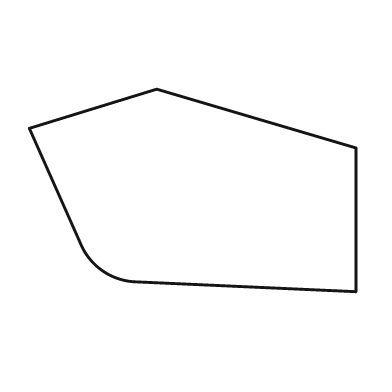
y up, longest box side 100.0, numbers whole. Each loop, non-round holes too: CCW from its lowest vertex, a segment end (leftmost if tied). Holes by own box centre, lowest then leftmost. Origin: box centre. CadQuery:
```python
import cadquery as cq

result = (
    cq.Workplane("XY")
    .moveTo(50.0, -31.0)
    .lineTo(50.0, 13.0)
    .lineTo(-11.0, 31.0)
    .lineTo(-50.0, 19.0)
    .lineTo(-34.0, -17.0)
    .threePointArc((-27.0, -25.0), (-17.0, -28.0))
    .close()
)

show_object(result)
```